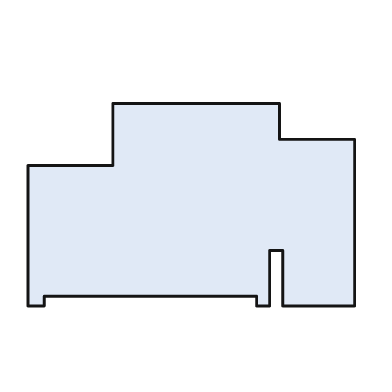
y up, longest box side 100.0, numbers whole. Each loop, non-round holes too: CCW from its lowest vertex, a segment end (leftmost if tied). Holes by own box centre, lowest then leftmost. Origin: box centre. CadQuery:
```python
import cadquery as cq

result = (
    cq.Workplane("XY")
    .moveTo(-50.0, -31.0)
    .lineTo(-45.0, -31.0)
    .lineTo(-45.0, -28.0)
    .lineTo(20.0, -28.0)
    .lineTo(20.0, -31.0)
    .lineTo(24.0, -31.0)
    .lineTo(24.0, -14.0)
    .lineTo(28.0, -14.0)
    .lineTo(28.0, -31.0)
    .lineTo(50.0, -31.0)
    .lineTo(50.0, 20.0)
    .lineTo(27.0, 20.0)
    .lineTo(27.0, 31.0)
    .lineTo(-24.0, 31.0)
    .lineTo(-24.0, 12.0)
    .lineTo(-50.0, 12.0)
    .close()
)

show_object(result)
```